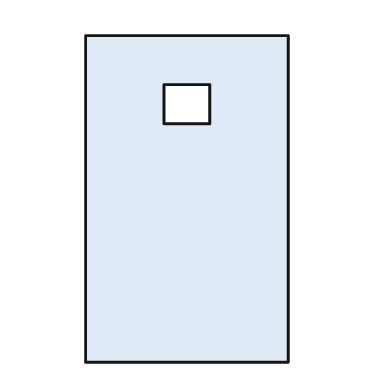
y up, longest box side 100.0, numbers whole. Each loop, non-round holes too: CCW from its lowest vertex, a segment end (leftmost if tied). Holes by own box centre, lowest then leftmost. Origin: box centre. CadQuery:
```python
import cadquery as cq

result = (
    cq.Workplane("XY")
    .moveTo(-31.0, -50.0)
    .lineTo(31.0, -50.0)
    .lineTo(31.0, 50.0)
    .lineTo(-31.0, 50.0)
    .close()
    .moveTo(-7.0, 23.0)
    .lineTo(7.0, 23.0)
    .lineTo(7.0, 35.0)
    .lineTo(-7.0, 35.0)
    .close()
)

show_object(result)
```